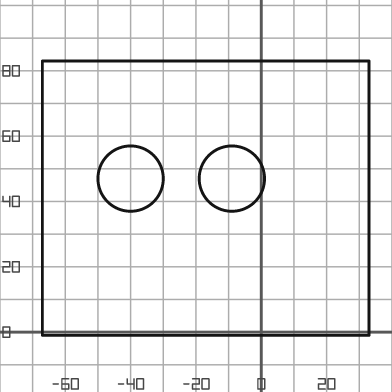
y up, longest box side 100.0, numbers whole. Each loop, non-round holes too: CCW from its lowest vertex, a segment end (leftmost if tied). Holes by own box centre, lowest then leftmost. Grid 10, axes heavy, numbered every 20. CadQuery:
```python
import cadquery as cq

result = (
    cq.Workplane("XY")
    .moveTo(-67.0, -1.0)
    .lineTo(33.0, -1.0)
    .lineTo(33.0, 83.0)
    .lineTo(-67.0, 83.0)
    .close()
    .moveTo(-40.0, 47.0)
    .circle(10.0)
    .moveTo(-9.0, 47.0)
    .circle(10.0)
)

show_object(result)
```